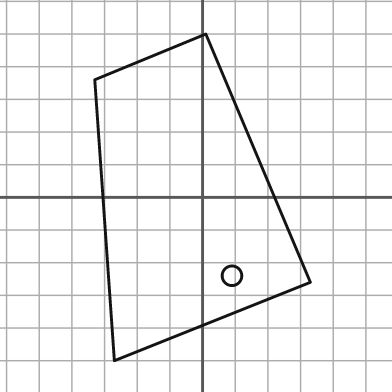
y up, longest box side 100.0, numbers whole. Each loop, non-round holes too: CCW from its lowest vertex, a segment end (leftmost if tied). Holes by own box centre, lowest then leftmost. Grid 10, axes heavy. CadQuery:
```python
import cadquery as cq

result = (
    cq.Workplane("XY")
    .moveTo(-27.0, -50.0)
    .lineTo(33.0, -26.0)
    .lineTo(1.0, 50.0)
    .lineTo(-33.0, 36.0)
    .close()
    .moveTo(9.0, -24.0)
    .circle(3.0)
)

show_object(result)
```